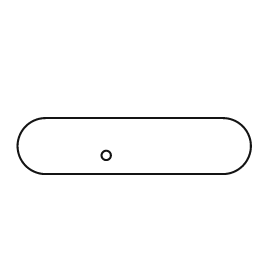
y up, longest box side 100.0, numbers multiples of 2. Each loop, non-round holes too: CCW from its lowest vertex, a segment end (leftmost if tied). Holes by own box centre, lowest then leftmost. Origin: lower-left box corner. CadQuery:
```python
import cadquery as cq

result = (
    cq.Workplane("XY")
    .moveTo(12.0, 0.0)
    .lineTo(88.0, 0.0)
    .threePointArc((100.0, 12.0), (88.0, 24.0))
    .lineTo(12.0, 24.0)
    .threePointArc((0.0, 12.0), (12.0, 0.0))
    .close()
    .moveTo(38.0, 8.0)
    .circle(2.0)
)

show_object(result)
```